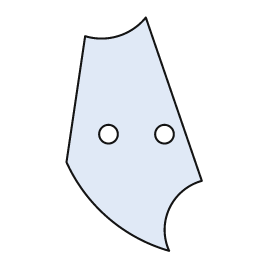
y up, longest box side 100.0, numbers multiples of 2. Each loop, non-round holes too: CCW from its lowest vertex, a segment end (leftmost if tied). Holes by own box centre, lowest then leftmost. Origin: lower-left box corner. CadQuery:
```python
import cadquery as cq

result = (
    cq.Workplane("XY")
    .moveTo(44.0, 0.0)
    .threePointArc((44.0, 18.0), (58.0, 30.0))
    .lineTo(34.0, 100.0)
    .threePointArc((22.0, 92.0), (8.0, 92.0))
    .lineTo(0.0, 38.0)
    .threePointArc((18.0, 14.0), (44.0, 0.0))
    .close()
    .moveTo(18.0, 50.0)
    .circle(4.0)
    .moveTo(42.0, 50.0)
    .circle(4.0)
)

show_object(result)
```